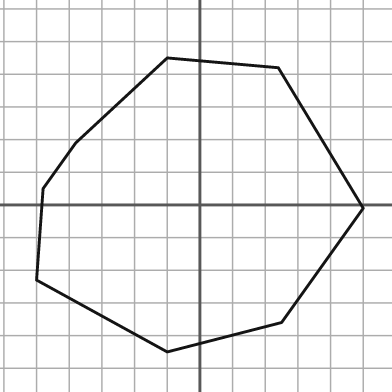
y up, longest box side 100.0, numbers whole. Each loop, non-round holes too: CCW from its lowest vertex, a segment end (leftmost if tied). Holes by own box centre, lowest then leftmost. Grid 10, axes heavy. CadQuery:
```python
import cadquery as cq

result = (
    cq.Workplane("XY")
    .moveTo(-10.0, -45.0)
    .lineTo(25.0, -36.0)
    .lineTo(50.0, -1.0)
    .lineTo(24.0, 42.0)
    .lineTo(-10.0, 45.0)
    .lineTo(-38.0, 19.0)
    .lineTo(-48.0, 5.0)
    .lineTo(-50.0, -23.0)
    .close()
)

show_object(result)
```